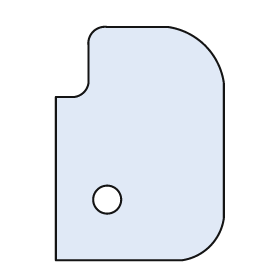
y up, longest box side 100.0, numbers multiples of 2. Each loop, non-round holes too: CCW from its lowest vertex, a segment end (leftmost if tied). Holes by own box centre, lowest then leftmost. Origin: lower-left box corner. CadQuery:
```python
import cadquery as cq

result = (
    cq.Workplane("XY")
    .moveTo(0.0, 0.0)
    .lineTo(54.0, 0.0)
    .threePointArc((66.0, 6.0), (72.0, 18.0))
    .lineTo(72.0, 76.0)
    .threePointArc((64.0, 92.0), (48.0, 100.0))
    .lineTo(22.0, 100.0)
    .threePointArc((16.0, 98.0), (14.0, 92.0))
    .lineTo(14.0, 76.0)
    .threePointArc((12.0, 72.0), (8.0, 70.0))
    .lineTo(0.0, 70.0)
    .close()
    .moveTo(22.0, 26.0)
    .circle(6.0)
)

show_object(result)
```